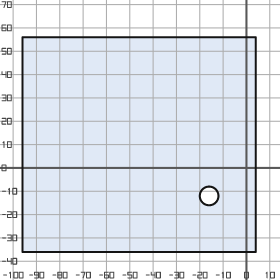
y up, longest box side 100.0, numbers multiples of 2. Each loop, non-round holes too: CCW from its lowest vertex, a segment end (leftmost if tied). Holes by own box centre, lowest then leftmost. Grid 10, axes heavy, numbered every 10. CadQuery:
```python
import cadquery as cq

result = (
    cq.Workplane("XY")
    .moveTo(-96.0, -36.0)
    .lineTo(4.0, -36.0)
    .lineTo(4.0, 56.0)
    .lineTo(-96.0, 56.0)
    .close()
    .moveTo(-16.0, -12.0)
    .circle(4.0)
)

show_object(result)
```